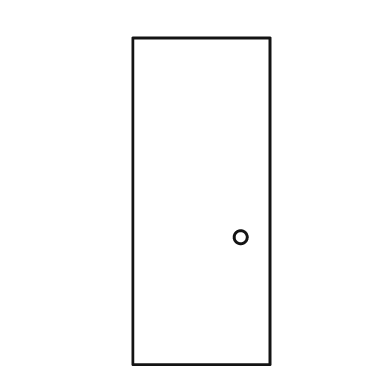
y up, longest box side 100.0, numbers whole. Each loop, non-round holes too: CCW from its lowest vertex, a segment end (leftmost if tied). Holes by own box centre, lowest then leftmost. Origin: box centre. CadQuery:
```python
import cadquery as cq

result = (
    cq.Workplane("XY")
    .moveTo(-21.0, -50.0)
    .lineTo(21.0, -50.0)
    .lineTo(21.0, 50.0)
    .lineTo(-21.0, 50.0)
    .close()
    .moveTo(12.0, -11.0)
    .circle(2.0)
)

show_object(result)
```